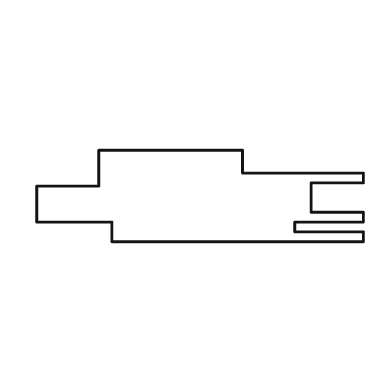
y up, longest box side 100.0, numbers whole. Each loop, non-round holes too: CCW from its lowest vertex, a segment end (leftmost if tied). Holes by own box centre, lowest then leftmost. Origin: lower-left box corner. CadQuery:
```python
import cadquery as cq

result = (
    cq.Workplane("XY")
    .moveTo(23.0, 0.0)
    .lineTo(100.0, 0.0)
    .lineTo(100.0, 3.0)
    .lineTo(79.0, 3.0)
    .lineTo(79.0, 6.0)
    .lineTo(100.0, 6.0)
    .lineTo(100.0, 9.0)
    .lineTo(84.0, 9.0)
    .lineTo(84.0, 18.0)
    .lineTo(100.0, 18.0)
    .lineTo(100.0, 21.0)
    .lineTo(63.0, 21.0)
    .lineTo(63.0, 28.0)
    .lineTo(19.0, 28.0)
    .lineTo(19.0, 17.0)
    .lineTo(0.0, 17.0)
    .lineTo(0.0, 6.0)
    .lineTo(23.0, 6.0)
    .close()
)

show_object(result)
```